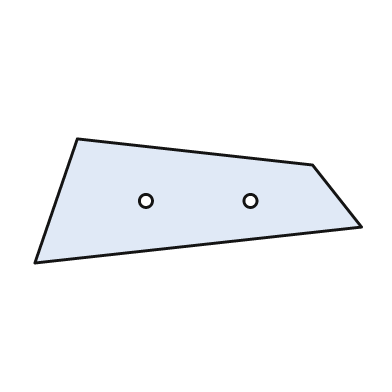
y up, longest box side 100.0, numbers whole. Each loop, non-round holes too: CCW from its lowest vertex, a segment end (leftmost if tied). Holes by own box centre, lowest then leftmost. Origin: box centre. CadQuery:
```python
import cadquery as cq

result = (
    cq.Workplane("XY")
    .moveTo(-50.0, -19.0)
    .lineTo(50.0, -8.0)
    .lineTo(35.0, 11.0)
    .lineTo(-37.0, 19.0)
    .close()
    .moveTo(-16.0, 0.0)
    .circle(2.0)
    .moveTo(16.0, 0.0)
    .circle(2.0)
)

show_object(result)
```